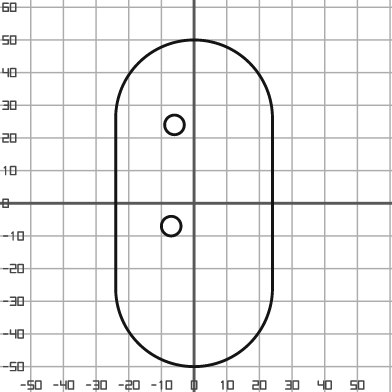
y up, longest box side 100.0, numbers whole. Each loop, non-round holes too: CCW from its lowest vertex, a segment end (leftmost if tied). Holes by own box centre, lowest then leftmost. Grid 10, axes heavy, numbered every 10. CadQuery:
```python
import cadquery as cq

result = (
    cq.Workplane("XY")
    .moveTo(-24.0, -26.0)
    .threePointArc((0.0, -50.0), (24.0, -26.0))
    .lineTo(24.0, 26.0)
    .threePointArc((0.0, 50.0), (-24.0, 26.0))
    .close()
    .moveTo(-7.0, -7.0)
    .circle(3.0)
    .moveTo(-6.0, 24.0)
    .circle(3.0)
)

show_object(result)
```